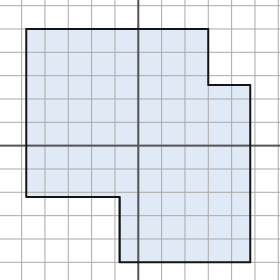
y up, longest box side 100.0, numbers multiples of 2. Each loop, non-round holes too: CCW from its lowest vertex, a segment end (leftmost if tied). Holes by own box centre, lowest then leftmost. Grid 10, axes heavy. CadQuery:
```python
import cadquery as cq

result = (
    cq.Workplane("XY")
    .moveTo(-8.0, -50.0)
    .lineTo(48.0, -50.0)
    .lineTo(48.0, 26.0)
    .lineTo(30.0, 26.0)
    .lineTo(30.0, 50.0)
    .lineTo(-48.0, 50.0)
    .lineTo(-48.0, -22.0)
    .lineTo(-8.0, -22.0)
    .close()
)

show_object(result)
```